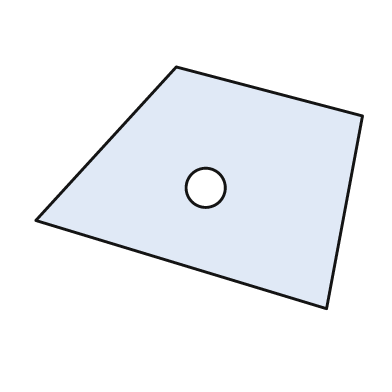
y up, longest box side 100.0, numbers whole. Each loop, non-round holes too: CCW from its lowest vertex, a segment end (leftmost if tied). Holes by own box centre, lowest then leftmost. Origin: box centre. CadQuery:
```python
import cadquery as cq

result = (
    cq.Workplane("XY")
    .moveTo(39.0, -37.0)
    .lineTo(50.0, 22.0)
    .lineTo(-7.0, 37.0)
    .lineTo(-50.0, -10.0)
    .close()
    .moveTo(2.0, 0.0)
    .circle(6.0)
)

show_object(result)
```